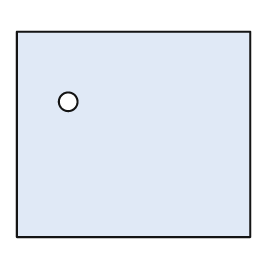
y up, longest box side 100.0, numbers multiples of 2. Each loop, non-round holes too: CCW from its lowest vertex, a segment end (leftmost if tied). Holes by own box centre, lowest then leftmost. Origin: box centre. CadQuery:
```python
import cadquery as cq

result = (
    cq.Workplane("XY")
    .moveTo(-50.0, -44.0)
    .lineTo(50.0, -44.0)
    .lineTo(50.0, 44.0)
    .lineTo(-50.0, 44.0)
    .close()
    .moveTo(-28.0, 14.0)
    .circle(4.0)
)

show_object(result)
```